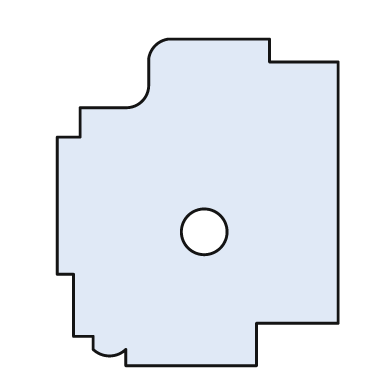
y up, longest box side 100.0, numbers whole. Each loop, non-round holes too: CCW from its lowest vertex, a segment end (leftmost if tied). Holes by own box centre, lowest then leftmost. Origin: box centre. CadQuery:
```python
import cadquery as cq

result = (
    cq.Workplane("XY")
    .moveTo(-22.0, -50.0)
    .lineTo(18.0, -50.0)
    .lineTo(18.0, -37.0)
    .lineTo(43.0, -37.0)
    .lineTo(43.0, 43.0)
    .lineTo(22.0, 43.0)
    .lineTo(22.0, 50.0)
    .lineTo(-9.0, 50.0)
    .threePointArc((-13.0, 48.0), (-15.0, 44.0))
    .lineTo(-15.0, 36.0)
    .threePointArc((-17.0, 31.0), (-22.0, 29.0))
    .lineTo(-36.0, 29.0)
    .lineTo(-36.0, 20.0)
    .lineTo(-43.0, 20.0)
    .lineTo(-43.0, -22.0)
    .lineTo(-38.0, -22.0)
    .lineTo(-38.0, -41.0)
    .lineTo(-32.0, -41.0)
    .lineTo(-32.0, -45.0)
    .threePointArc((-27.0, -47.0), (-22.0, -45.0))
    .close()
    .moveTo(2.0, -9.0)
    .circle(7.0)
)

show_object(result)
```